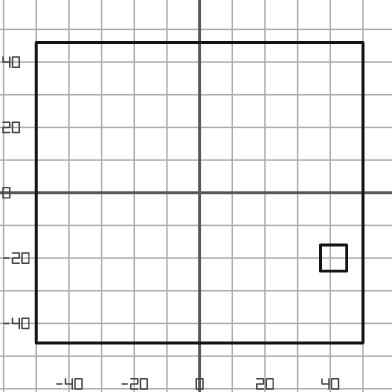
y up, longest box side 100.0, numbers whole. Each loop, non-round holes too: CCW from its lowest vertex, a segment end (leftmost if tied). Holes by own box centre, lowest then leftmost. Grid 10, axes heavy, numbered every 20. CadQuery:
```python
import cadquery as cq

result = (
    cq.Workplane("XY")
    .moveTo(-50.0, -46.0)
    .lineTo(50.0, -46.0)
    .lineTo(50.0, 46.0)
    .lineTo(-50.0, 46.0)
    .close()
    .moveTo(37.0, -24.0)
    .lineTo(45.0, -24.0)
    .lineTo(45.0, -16.0)
    .lineTo(37.0, -16.0)
    .close()
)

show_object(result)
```